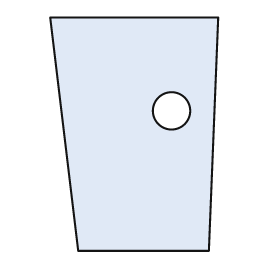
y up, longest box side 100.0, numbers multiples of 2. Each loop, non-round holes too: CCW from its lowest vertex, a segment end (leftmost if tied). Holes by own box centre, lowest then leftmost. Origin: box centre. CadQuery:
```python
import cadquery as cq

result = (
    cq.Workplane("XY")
    .moveTo(-24.0, -50.0)
    .lineTo(32.0, -50.0)
    .lineTo(36.0, 50.0)
    .lineTo(-36.0, 50.0)
    .close()
    .moveTo(16.0, 10.0)
    .circle(8.0)
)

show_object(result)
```